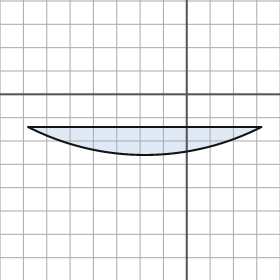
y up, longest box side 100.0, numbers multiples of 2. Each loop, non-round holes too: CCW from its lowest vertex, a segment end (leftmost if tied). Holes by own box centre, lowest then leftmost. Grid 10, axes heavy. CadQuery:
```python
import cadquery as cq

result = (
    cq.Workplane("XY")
    .moveTo(-68.0, -14.0)
    .threePointArc((-18.0, -26.0), (32.0, -14.0))
    .close()
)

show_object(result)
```